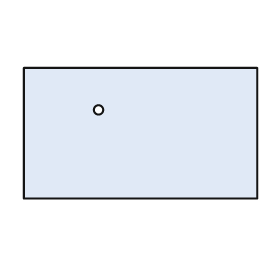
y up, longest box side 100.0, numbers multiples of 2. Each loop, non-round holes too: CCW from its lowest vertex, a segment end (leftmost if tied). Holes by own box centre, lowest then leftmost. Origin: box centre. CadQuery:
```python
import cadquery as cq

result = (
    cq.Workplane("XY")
    .moveTo(-50.0, -28.0)
    .lineTo(50.0, -28.0)
    .lineTo(50.0, 28.0)
    .lineTo(-50.0, 28.0)
    .close()
    .moveTo(-18.0, 10.0)
    .circle(2.0)
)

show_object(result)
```